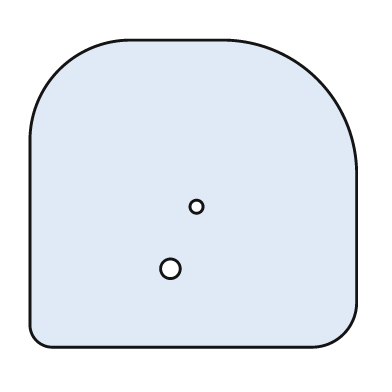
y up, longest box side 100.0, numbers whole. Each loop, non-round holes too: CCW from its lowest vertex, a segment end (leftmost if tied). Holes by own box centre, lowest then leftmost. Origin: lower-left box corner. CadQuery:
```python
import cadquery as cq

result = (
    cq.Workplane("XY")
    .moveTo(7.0, 0.0)
    .lineTo(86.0, 0.0)
    .threePointArc((96.0, 4.0), (100.0, 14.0))
    .lineTo(100.0, 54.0)
    .threePointArc((88.0, 82.0), (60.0, 94.0))
    .lineTo(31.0, 94.0)
    .threePointArc((9.0, 85.0), (0.0, 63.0))
    .lineTo(0.0, 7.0)
    .threePointArc((2.0, 2.0), (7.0, 0.0))
    .close()
    .moveTo(43.0, 24.0)
    .circle(3.0)
    .moveTo(51.0, 43.0)
    .circle(2.0)
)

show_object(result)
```